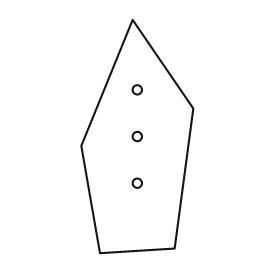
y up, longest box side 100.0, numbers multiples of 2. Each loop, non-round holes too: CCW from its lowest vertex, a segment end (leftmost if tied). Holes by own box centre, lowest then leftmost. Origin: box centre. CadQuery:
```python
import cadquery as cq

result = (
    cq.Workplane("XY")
    .moveTo(-16.0, -50.0)
    .lineTo(16.0, -48.0)
    .lineTo(24.0, 12.0)
    .lineTo(-2.0, 50.0)
    .lineTo(-24.0, -4.0)
    .close()
    .moveTo(0.0, -20.0)
    .circle(2.0)
    .moveTo(0.0, 0.0)
    .circle(2.0)
    .moveTo(0.0, 20.0)
    .circle(2.0)
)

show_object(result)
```